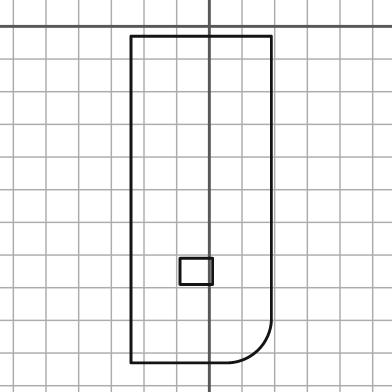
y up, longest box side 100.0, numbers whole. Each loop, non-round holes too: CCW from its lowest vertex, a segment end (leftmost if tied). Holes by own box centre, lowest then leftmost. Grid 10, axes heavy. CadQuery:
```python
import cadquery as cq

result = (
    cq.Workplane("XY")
    .moveTo(-24.0, -103.0)
    .lineTo(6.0, -103.0)
    .threePointArc((15.0, -99.0), (19.0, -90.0))
    .lineTo(19.0, -3.0)
    .lineTo(-24.0, -3.0)
    .close()
    .moveTo(-9.0, -79.0)
    .lineTo(1.0, -79.0)
    .lineTo(1.0, -71.0)
    .lineTo(-9.0, -71.0)
    .close()
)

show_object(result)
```